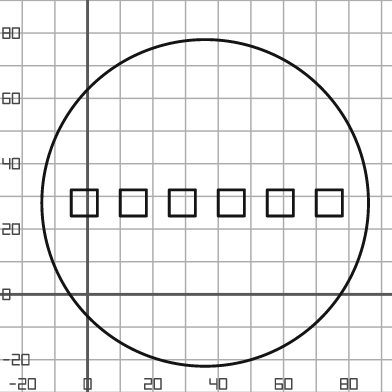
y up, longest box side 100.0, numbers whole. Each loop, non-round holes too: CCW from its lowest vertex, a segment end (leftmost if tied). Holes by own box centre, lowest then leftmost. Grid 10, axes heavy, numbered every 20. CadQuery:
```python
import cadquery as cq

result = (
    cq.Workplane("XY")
    .moveTo(36.0, 28.0)
    .circle(50.0)
    .moveTo(-5.0, 24.0)
    .lineTo(3.0, 24.0)
    .lineTo(3.0, 32.0)
    .lineTo(-5.0, 32.0)
    .close()
    .moveTo(10.0, 24.0)
    .lineTo(18.0, 24.0)
    .lineTo(18.0, 32.0)
    .lineTo(10.0, 32.0)
    .close()
    .moveTo(25.0, 24.0)
    .lineTo(33.0, 24.0)
    .lineTo(33.0, 32.0)
    .lineTo(25.0, 32.0)
    .close()
    .moveTo(40.0, 24.0)
    .lineTo(48.0, 24.0)
    .lineTo(48.0, 32.0)
    .lineTo(40.0, 32.0)
    .close()
    .moveTo(55.0, 24.0)
    .lineTo(63.0, 24.0)
    .lineTo(63.0, 32.0)
    .lineTo(55.0, 32.0)
    .close()
    .moveTo(70.0, 24.0)
    .lineTo(78.0, 24.0)
    .lineTo(78.0, 32.0)
    .lineTo(70.0, 32.0)
    .close()
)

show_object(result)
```